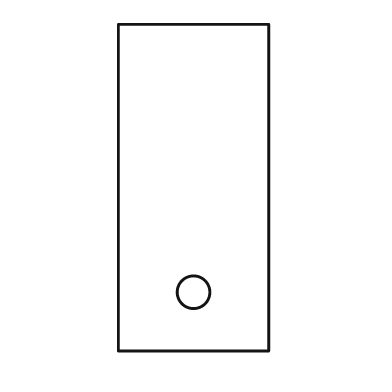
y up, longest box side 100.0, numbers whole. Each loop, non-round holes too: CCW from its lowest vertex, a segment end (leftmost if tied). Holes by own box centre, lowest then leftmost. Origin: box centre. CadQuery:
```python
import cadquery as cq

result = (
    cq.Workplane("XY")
    .moveTo(-23.0, -50.0)
    .lineTo(23.0, -50.0)
    .lineTo(23.0, 50.0)
    .lineTo(-23.0, 50.0)
    .close()
    .moveTo(0.0, -32.0)
    .circle(5.0)
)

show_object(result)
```